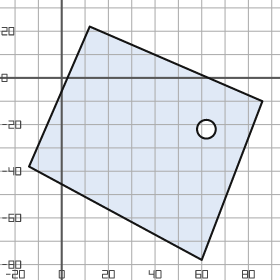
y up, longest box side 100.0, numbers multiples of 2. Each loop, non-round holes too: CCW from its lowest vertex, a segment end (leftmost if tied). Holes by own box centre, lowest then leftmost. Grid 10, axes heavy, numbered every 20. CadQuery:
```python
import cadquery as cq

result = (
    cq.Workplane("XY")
    .moveTo(60.0, -78.0)
    .lineTo(86.0, -10.0)
    .lineTo(12.0, 22.0)
    .lineTo(-14.0, -38.0)
    .close()
    .moveTo(62.0, -22.0)
    .circle(4.0)
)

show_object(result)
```